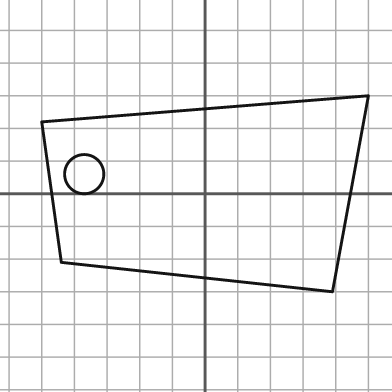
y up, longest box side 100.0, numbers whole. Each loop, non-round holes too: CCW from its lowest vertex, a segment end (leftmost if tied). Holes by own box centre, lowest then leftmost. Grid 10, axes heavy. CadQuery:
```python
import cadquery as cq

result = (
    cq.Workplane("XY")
    .moveTo(39.0, -30.0)
    .lineTo(50.0, 30.0)
    .lineTo(-50.0, 22.0)
    .lineTo(-44.0, -21.0)
    .close()
    .moveTo(-37.0, 6.0)
    .circle(6.0)
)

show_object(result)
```